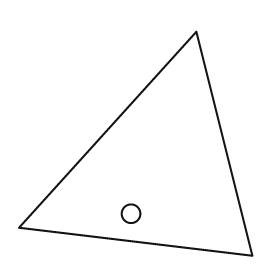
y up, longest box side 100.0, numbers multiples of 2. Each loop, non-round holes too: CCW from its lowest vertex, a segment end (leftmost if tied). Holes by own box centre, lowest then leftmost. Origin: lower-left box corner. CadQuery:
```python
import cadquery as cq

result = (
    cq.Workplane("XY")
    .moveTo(100.0, 0.0)
    .lineTo(76.0, 96.0)
    .lineTo(0.0, 12.0)
    .close()
    .moveTo(48.0, 18.0)
    .circle(4.0)
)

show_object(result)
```